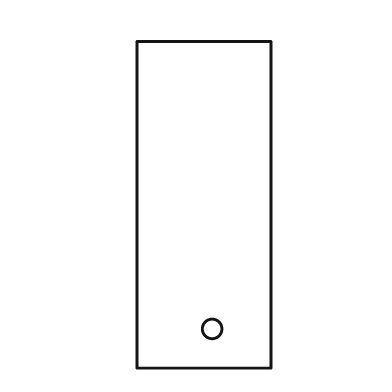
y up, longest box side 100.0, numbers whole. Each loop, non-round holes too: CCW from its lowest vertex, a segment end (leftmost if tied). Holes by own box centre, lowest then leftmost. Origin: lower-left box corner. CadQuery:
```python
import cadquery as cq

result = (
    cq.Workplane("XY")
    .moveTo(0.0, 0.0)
    .lineTo(41.0, 0.0)
    .lineTo(41.0, 100.0)
    .lineTo(0.0, 100.0)
    .close()
    .moveTo(23.0, 12.0)
    .circle(3.0)
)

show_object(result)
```